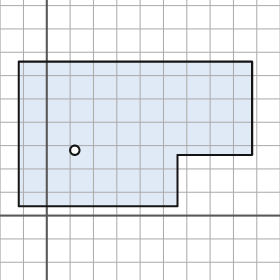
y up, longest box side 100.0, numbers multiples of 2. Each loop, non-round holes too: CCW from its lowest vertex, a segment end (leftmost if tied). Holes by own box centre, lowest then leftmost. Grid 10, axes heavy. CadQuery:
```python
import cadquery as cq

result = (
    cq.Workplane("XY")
    .moveTo(-12.0, 4.0)
    .lineTo(56.0, 4.0)
    .lineTo(56.0, 26.0)
    .lineTo(88.0, 26.0)
    .lineTo(88.0, 66.0)
    .lineTo(-12.0, 66.0)
    .close()
    .moveTo(12.0, 28.0)
    .circle(2.0)
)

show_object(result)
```